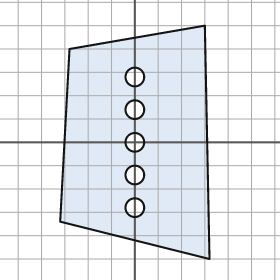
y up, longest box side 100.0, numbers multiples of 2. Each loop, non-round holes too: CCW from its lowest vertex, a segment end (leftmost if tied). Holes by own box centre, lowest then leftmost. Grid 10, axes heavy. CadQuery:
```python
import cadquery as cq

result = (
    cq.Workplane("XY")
    .moveTo(32.0, -50.0)
    .lineTo(30.0, 50.0)
    .lineTo(-28.0, 40.0)
    .lineTo(-32.0, -34.0)
    .close()
    .moveTo(0.0, -28.0)
    .circle(4.0)
    .moveTo(0.0, -14.0)
    .circle(4.0)
    .moveTo(0.0, 0.0)
    .circle(4.0)
    .moveTo(0.0, 14.0)
    .circle(4.0)
    .moveTo(0.0, 28.0)
    .circle(4.0)
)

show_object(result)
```